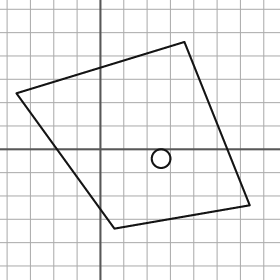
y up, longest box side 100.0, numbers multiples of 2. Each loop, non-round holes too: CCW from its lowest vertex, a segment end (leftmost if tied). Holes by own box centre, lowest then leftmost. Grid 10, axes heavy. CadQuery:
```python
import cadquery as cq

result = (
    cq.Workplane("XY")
    .moveTo(6.0, -34.0)
    .lineTo(64.0, -24.0)
    .lineTo(36.0, 46.0)
    .lineTo(-36.0, 24.0)
    .close()
    .moveTo(26.0, -4.0)
    .circle(4.0)
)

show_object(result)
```